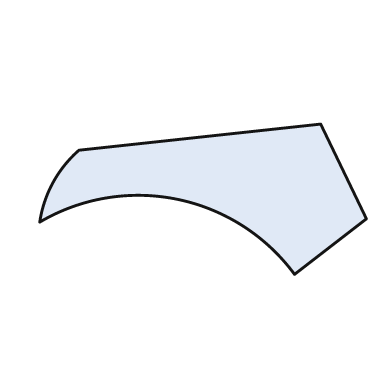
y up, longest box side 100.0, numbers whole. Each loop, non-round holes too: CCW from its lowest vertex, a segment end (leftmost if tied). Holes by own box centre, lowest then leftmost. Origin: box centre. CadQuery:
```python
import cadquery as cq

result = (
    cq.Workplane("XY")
    .moveTo(28.0, -23.0)
    .lineTo(50.0, -6.0)
    .lineTo(36.0, 23.0)
    .lineTo(-38.0, 15.0)
    .threePointArc((-46.0, 5.0), (-50.0, -7.0))
    .threePointArc((-8.0, 0.0), (28.0, -23.0))
    .close()
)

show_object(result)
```